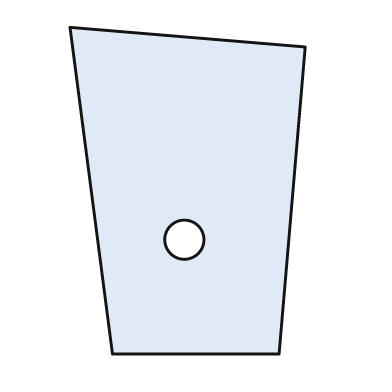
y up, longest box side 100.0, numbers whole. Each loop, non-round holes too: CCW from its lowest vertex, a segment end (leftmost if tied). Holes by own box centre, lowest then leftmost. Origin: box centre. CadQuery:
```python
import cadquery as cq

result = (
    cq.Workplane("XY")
    .moveTo(-23.0, -50.0)
    .lineTo(28.0, -50.0)
    .lineTo(36.0, 44.0)
    .lineTo(-36.0, 50.0)
    .close()
    .moveTo(-1.0, -15.0)
    .circle(6.0)
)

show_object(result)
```